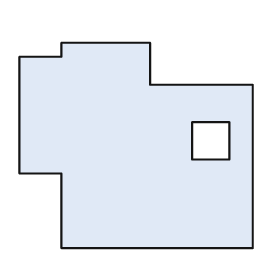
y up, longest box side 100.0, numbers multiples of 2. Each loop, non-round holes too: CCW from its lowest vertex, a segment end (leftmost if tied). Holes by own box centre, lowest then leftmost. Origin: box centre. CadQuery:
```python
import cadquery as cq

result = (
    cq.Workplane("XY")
    .moveTo(-32.0, -44.0)
    .lineTo(50.0, -44.0)
    .lineTo(50.0, 26.0)
    .lineTo(6.0, 26.0)
    .lineTo(6.0, 44.0)
    .lineTo(-32.0, 44.0)
    .lineTo(-32.0, 38.0)
    .lineTo(-50.0, 38.0)
    .lineTo(-50.0, -12.0)
    .lineTo(-32.0, -12.0)
    .close()
    .moveTo(24.0, -6.0)
    .lineTo(40.0, -6.0)
    .lineTo(40.0, 10.0)
    .lineTo(24.0, 10.0)
    .close()
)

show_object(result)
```